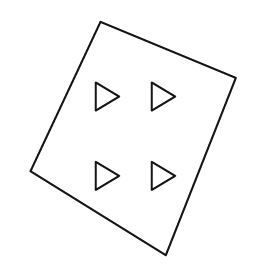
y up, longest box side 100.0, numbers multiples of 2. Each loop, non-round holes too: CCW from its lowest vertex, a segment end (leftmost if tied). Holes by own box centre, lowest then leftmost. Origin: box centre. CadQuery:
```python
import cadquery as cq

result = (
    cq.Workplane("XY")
    .moveTo(14.0, -50.0)
    .lineTo(44.0, 26.0)
    .lineTo(-14.0, 50.0)
    .lineTo(-44.0, -14.0)
    .close()
    .moveTo(-16.0, -22.0)
    .lineTo(-6.0, -16.0)
    .lineTo(-16.0, -10.0)
    .close()
    .moveTo(8.0, -22.0)
    .lineTo(18.0, -16.0)
    .lineTo(8.0, -10.0)
    .close()
    .moveTo(-16.0, 12.0)
    .lineTo(-6.0, 18.0)
    .lineTo(-16.0, 24.0)
    .close()
    .moveTo(8.0, 12.0)
    .lineTo(18.0, 18.0)
    .lineTo(8.0, 24.0)
    .close()
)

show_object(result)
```